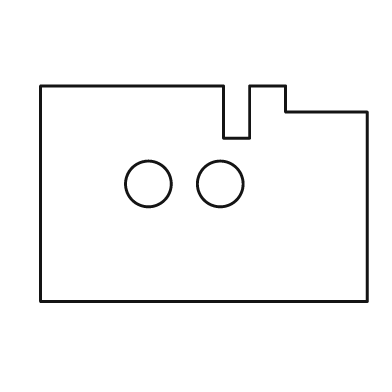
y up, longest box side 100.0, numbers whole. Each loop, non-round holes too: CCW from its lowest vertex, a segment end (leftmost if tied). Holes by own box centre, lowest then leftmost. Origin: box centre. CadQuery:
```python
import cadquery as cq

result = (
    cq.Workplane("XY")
    .moveTo(-50.0, -33.0)
    .lineTo(50.0, -33.0)
    .lineTo(50.0, 25.0)
    .lineTo(25.0, 25.0)
    .lineTo(25.0, 33.0)
    .lineTo(14.0, 33.0)
    .lineTo(14.0, 17.0)
    .lineTo(6.0, 17.0)
    .lineTo(6.0, 33.0)
    .lineTo(-50.0, 33.0)
    .close()
    .moveTo(-17.0, 3.0)
    .circle(7.0)
    .moveTo(5.0, 3.0)
    .circle(7.0)
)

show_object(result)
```